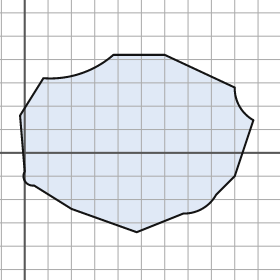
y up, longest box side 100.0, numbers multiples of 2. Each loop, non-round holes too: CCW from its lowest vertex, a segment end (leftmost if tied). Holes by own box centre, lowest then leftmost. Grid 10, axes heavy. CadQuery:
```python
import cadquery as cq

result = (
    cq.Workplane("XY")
    .moveTo(48.0, -34.0)
    .lineTo(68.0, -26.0)
    .threePointArc((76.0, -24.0), (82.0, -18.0))
    .lineTo(90.0, -10.0)
    .lineTo(98.0, 14.0)
    .threePointArc((92.0, 20.0), (90.0, 28.0))
    .lineTo(60.0, 42.0)
    .lineTo(38.0, 42.0)
    .threePointArc((24.0, 34.0), (8.0, 32.0))
    .lineTo(-2.0, 16.0)
    .lineTo(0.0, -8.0)
    .threePointArc((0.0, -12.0), (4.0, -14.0))
    .lineTo(20.0, -24.0)
    .close()
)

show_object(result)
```